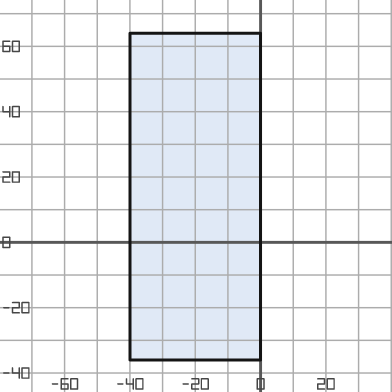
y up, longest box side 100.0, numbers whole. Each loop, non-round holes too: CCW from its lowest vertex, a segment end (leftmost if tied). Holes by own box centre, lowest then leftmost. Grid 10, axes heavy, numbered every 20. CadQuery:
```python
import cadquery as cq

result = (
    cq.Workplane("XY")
    .moveTo(-40.0, -36.0)
    .lineTo(0.0, -36.0)
    .lineTo(0.0, 64.0)
    .lineTo(-40.0, 64.0)
    .close()
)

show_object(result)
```